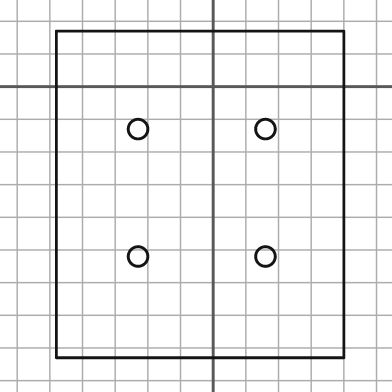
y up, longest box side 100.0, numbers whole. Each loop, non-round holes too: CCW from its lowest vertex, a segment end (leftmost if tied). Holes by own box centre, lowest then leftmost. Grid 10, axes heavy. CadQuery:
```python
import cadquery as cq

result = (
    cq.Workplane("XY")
    .moveTo(-48.0, -83.0)
    .lineTo(40.0, -83.0)
    .lineTo(40.0, 17.0)
    .lineTo(-48.0, 17.0)
    .close()
    .moveTo(-23.0, -52.0)
    .circle(3.0)
    .moveTo(16.0, -52.0)
    .circle(3.0)
    .moveTo(-23.0, -13.0)
    .circle(3.0)
    .moveTo(16.0, -13.0)
    .circle(3.0)
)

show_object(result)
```